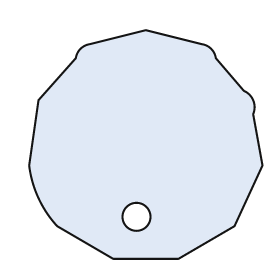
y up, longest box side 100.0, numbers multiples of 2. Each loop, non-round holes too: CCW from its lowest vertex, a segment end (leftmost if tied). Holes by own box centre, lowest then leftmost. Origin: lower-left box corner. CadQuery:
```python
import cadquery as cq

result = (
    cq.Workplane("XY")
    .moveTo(36.0, 0.0)
    .lineTo(64.0, 0.0)
    .lineTo(88.0, 14.0)
    .lineTo(100.0, 40.0)
    .lineTo(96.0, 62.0)
    .threePointArc((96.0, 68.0), (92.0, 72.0))
    .lineTo(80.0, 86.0)
    .threePointArc((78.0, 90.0), (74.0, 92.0))
    .lineTo(50.0, 98.0)
    .lineTo(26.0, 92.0)
    .threePointArc((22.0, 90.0), (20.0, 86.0))
    .lineTo(4.0, 68.0)
    .lineTo(0.0, 40.0)
    .threePointArc((4.0, 26.0), (12.0, 14.0))
    .close()
    .moveTo(46.0, 18.0)
    .circle(6.0)
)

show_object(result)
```